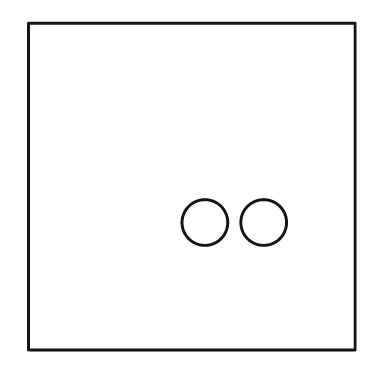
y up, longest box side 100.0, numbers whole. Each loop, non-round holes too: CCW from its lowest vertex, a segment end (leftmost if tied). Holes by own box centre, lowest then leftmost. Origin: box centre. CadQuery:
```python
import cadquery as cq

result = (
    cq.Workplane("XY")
    .moveTo(-50.0, -50.0)
    .lineTo(50.0, -50.0)
    .lineTo(50.0, 50.0)
    .lineTo(-50.0, 50.0)
    .close()
    .moveTo(4.0, -11.0)
    .circle(7.0)
    .moveTo(22.0, -11.0)
    .circle(7.0)
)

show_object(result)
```